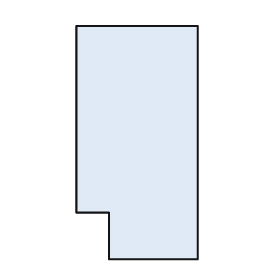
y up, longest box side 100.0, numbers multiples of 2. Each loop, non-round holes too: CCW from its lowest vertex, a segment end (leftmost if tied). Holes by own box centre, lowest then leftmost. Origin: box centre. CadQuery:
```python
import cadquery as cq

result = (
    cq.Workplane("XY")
    .moveTo(-12.0, -50.0)
    .lineTo(26.0, -50.0)
    .lineTo(26.0, 50.0)
    .lineTo(-26.0, 50.0)
    .lineTo(-26.0, -30.0)
    .lineTo(-12.0, -30.0)
    .close()
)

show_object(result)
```